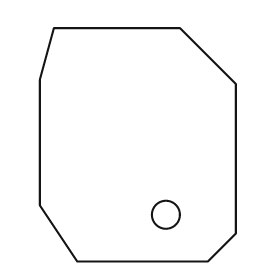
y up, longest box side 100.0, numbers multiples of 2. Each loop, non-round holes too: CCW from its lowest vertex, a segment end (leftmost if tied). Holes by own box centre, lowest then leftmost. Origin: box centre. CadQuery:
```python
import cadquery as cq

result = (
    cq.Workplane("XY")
    .moveTo(-26.0, -50.0)
    .lineTo(30.0, -50.0)
    .lineTo(42.0, -38.0)
    .lineTo(42.0, 26.0)
    .lineTo(18.0, 50.0)
    .lineTo(-36.0, 50.0)
    .lineTo(-42.0, 28.0)
    .lineTo(-42.0, -26.0)
    .close()
    .moveTo(12.0, -30.0)
    .circle(6.0)
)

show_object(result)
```